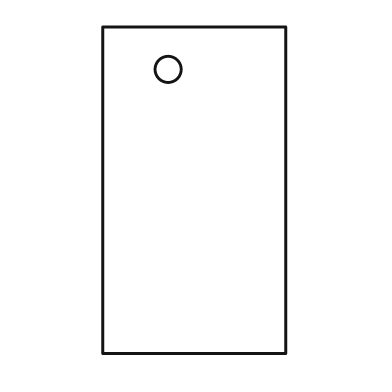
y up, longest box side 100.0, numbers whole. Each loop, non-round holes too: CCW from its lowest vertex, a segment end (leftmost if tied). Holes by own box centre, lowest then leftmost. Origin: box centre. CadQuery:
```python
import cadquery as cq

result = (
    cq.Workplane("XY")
    .moveTo(-28.0, -50.0)
    .lineTo(28.0, -50.0)
    .lineTo(28.0, 50.0)
    .lineTo(-28.0, 50.0)
    .close()
    .moveTo(-8.0, 37.0)
    .circle(4.0)
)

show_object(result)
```